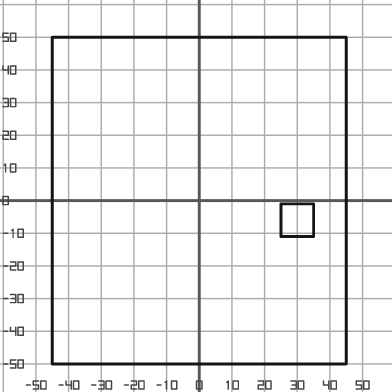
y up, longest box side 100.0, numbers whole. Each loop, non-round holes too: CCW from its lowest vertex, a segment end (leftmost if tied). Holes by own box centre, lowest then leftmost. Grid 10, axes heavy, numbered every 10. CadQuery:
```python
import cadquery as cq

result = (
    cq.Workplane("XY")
    .moveTo(-45.0, -50.0)
    .lineTo(45.0, -50.0)
    .lineTo(45.0, 50.0)
    .lineTo(-45.0, 50.0)
    .close()
    .moveTo(25.0, -11.0)
    .lineTo(35.0, -11.0)
    .lineTo(35.0, -1.0)
    .lineTo(25.0, -1.0)
    .close()
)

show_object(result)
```